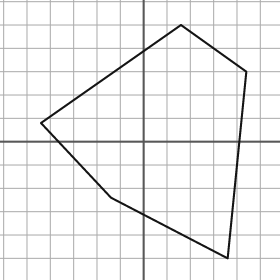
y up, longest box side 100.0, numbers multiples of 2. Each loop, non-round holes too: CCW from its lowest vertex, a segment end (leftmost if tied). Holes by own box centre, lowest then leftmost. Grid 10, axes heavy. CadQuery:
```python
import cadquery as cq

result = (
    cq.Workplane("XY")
    .moveTo(36.0, -50.0)
    .lineTo(44.0, 30.0)
    .lineTo(16.0, 50.0)
    .lineTo(-44.0, 8.0)
    .lineTo(-14.0, -24.0)
    .close()
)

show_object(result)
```